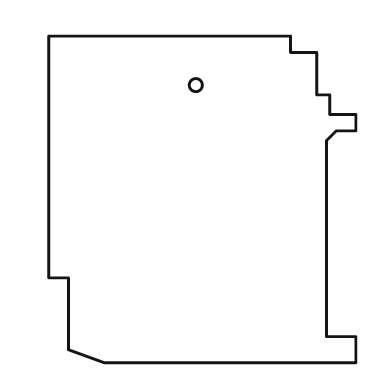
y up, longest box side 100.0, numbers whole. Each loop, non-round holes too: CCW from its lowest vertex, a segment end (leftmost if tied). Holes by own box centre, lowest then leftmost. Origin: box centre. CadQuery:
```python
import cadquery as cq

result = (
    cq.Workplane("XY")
    .moveTo(-30.0, -50.0)
    .lineTo(47.0, -50.0)
    .lineTo(47.0, -42.0)
    .lineTo(38.0, -42.0)
    .lineTo(38.0, 18.0)
    .lineTo(41.0, 21.0)
    .lineTo(47.0, 21.0)
    .lineTo(47.0, 26.0)
    .lineTo(39.0, 26.0)
    .lineTo(39.0, 32.0)
    .lineTo(35.0, 32.0)
    .lineTo(35.0, 45.0)
    .lineTo(27.0, 45.0)
    .lineTo(27.0, 50.0)
    .lineTo(-47.0, 50.0)
    .lineTo(-47.0, -24.0)
    .lineTo(-41.0, -24.0)
    .lineTo(-41.0, -46.0)
    .close()
    .moveTo(-2.0, 35.0)
    .circle(2.0)
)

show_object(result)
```